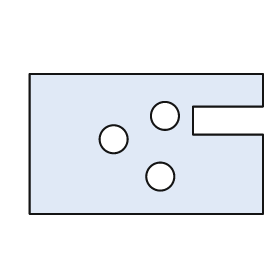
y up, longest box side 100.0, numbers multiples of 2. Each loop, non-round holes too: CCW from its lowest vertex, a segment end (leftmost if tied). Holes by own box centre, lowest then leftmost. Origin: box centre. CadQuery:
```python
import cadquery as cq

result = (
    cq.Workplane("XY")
    .moveTo(-50.0, -30.0)
    .lineTo(50.0, -30.0)
    .lineTo(50.0, 4.0)
    .lineTo(20.0, 4.0)
    .lineTo(20.0, 16.0)
    .lineTo(50.0, 16.0)
    .lineTo(50.0, 30.0)
    .lineTo(-50.0, 30.0)
    .close()
    .moveTo(6.0, -14.0)
    .circle(6.0)
    .moveTo(-14.0, 2.0)
    .circle(6.0)
    .moveTo(8.0, 12.0)
    .circle(6.0)
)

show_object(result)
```